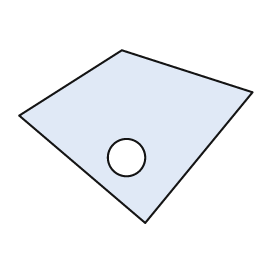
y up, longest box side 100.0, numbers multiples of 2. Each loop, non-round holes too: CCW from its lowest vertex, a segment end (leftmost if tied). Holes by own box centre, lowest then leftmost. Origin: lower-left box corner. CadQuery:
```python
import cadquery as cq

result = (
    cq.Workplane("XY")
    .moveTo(54.0, 0.0)
    .lineTo(100.0, 56.0)
    .lineTo(44.0, 74.0)
    .lineTo(0.0, 46.0)
    .close()
    .moveTo(46.0, 28.0)
    .circle(8.0)
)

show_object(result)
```